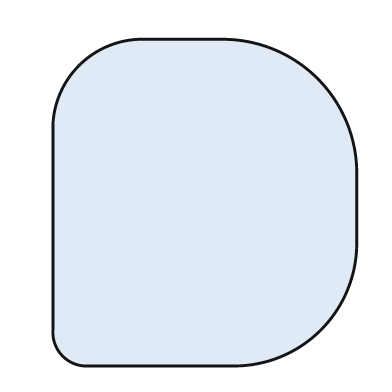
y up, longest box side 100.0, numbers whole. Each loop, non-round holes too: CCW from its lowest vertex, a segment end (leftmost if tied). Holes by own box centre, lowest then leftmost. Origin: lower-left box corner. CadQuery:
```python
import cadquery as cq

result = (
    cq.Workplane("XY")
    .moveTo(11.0, 0.0)
    .lineTo(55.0, 0.0)
    .threePointArc((82.0, 11.0), (93.0, 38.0))
    .lineTo(93.0, 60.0)
    .threePointArc((81.0, 88.0), (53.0, 100.0))
    .lineTo(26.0, 100.0)
    .threePointArc((8.0, 92.0), (0.0, 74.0))
    .lineTo(0.0, 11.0)
    .threePointArc((3.0, 3.0), (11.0, 0.0))
    .close()
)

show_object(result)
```